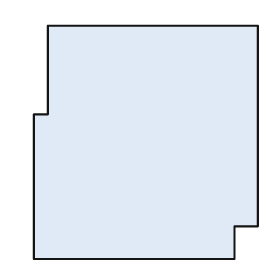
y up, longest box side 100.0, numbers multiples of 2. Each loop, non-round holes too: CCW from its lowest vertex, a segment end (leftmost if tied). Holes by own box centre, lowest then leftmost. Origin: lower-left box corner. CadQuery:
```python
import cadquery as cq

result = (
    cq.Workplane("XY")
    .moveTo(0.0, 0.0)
    .lineTo(86.0, 0.0)
    .lineTo(86.0, 14.0)
    .lineTo(96.0, 14.0)
    .lineTo(96.0, 100.0)
    .lineTo(6.0, 100.0)
    .lineTo(6.0, 62.0)
    .lineTo(0.0, 62.0)
    .close()
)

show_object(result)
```